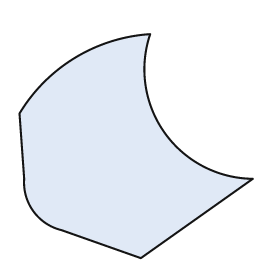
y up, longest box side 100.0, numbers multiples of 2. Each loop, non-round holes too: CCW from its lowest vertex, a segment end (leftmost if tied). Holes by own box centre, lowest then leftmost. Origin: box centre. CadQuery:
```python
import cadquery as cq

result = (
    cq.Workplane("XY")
    .moveTo(2.0, -48.0)
    .lineTo(50.0, -14.0)
    .threePointArc((12.0, 6.0), (6.0, 48.0))
    .threePointArc((-26.0, 38.0), (-50.0, 14.0))
    .lineTo(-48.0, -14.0)
    .threePointArc((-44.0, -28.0), (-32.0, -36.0))
    .close()
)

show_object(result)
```